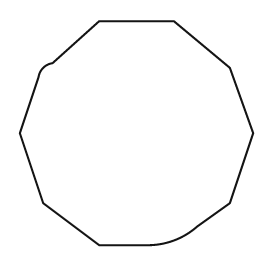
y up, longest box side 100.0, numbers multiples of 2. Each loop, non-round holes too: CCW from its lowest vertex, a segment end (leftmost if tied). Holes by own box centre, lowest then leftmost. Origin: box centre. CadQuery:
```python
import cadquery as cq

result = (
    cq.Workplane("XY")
    .moveTo(-16.0, -48.0)
    .lineTo(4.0, -48.0)
    .threePointArc((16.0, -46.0), (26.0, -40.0))
    .lineTo(40.0, -30.0)
    .lineTo(50.0, 0.0)
    .lineTo(40.0, 28.0)
    .lineTo(16.0, 48.0)
    .lineTo(-16.0, 48.0)
    .lineTo(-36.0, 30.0)
    .threePointArc((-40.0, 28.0), (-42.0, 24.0))
    .lineTo(-50.0, 0.0)
    .lineTo(-40.0, -30.0)
    .close()
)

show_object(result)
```